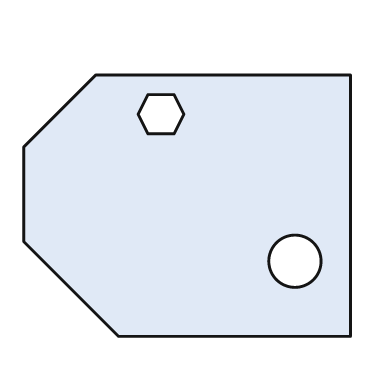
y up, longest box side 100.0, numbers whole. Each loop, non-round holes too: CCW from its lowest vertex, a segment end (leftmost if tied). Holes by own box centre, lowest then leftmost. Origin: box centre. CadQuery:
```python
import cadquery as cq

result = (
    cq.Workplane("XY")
    .moveTo(-21.0, -40.0)
    .lineTo(50.0, -40.0)
    .lineTo(50.0, 40.0)
    .lineTo(-28.0, 40.0)
    .lineTo(-50.0, 18.0)
    .lineTo(-50.0, -11.0)
    .close()
    .moveTo(33.0, -17.0)
    .circle(8.0)
    .moveTo(-12.0, 22.0)
    .lineTo(-4.0, 22.0)
    .lineTo(-1.0, 28.0)
    .lineTo(-4.0, 34.0)
    .lineTo(-12.0, 34.0)
    .lineTo(-15.0, 28.0)
    .close()
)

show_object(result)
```